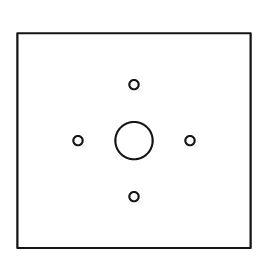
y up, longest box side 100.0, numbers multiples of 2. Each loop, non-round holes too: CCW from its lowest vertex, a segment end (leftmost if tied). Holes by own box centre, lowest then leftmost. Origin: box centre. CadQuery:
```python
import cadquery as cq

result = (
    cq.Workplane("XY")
    .moveTo(-50.0, -46.0)
    .lineTo(50.0, -46.0)
    .lineTo(50.0, 46.0)
    .lineTo(-50.0, 46.0)
    .close()
    .moveTo(0.0, -24.0)
    .circle(2.0)
    .moveTo(-24.0, 0.0)
    .circle(2.0)
    .moveTo(0.0, 0.0)
    .circle(8.0)
    .moveTo(24.0, 0.0)
    .circle(2.0)
    .moveTo(0.0, 24.0)
    .circle(2.0)
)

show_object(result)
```